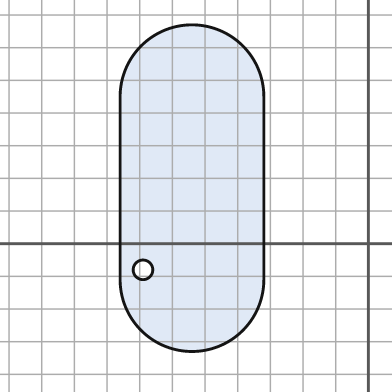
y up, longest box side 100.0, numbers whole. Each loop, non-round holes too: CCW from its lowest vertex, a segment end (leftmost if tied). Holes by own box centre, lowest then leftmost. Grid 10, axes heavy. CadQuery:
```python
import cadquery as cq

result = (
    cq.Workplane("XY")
    .moveTo(-76.0, -11.0)
    .threePointArc((-54.0, -33.0), (-32.0, -11.0))
    .lineTo(-32.0, 45.0)
    .threePointArc((-54.0, 67.0), (-76.0, 45.0))
    .close()
    .moveTo(-69.0, -8.0)
    .circle(3.0)
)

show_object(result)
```